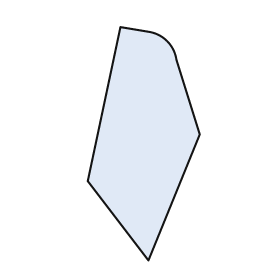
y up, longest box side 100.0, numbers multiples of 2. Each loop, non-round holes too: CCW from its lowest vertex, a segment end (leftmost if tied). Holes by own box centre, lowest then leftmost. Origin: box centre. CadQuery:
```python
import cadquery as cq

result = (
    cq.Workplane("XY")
    .moveTo(2.0, -50.0)
    .lineTo(24.0, 4.0)
    .lineTo(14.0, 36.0)
    .threePointArc((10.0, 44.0), (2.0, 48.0))
    .lineTo(-10.0, 50.0)
    .lineTo(-24.0, -16.0)
    .close()
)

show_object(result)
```